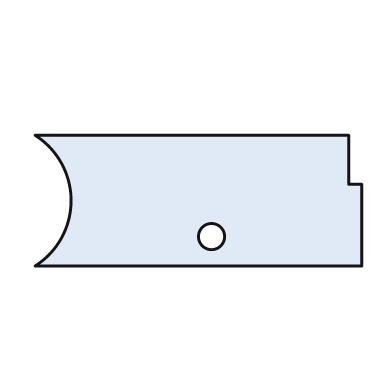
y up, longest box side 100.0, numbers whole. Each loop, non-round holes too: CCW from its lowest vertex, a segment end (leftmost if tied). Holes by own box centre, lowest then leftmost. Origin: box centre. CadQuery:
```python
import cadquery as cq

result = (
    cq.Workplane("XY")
    .moveTo(-50.0, -20.0)
    .lineTo(50.0, -20.0)
    .lineTo(50.0, 5.0)
    .lineTo(46.0, 5.0)
    .lineTo(46.0, 20.0)
    .lineTo(-50.0, 20.0)
    .threePointArc((-39.0, 0.0), (-50.0, -20.0))
    .close()
    .moveTo(4.0, -11.0)
    .circle(4.0)
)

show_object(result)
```